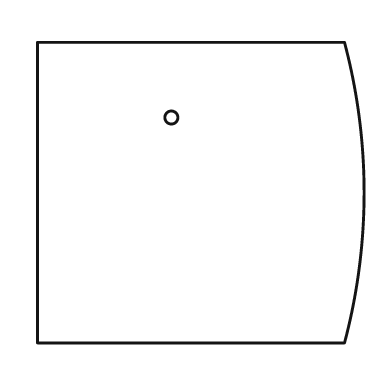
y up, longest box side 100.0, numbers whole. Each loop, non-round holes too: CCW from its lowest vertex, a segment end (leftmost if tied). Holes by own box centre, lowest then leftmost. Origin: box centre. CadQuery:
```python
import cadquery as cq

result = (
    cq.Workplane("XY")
    .moveTo(-50.0, -46.0)
    .lineTo(44.0, -46.0)
    .threePointArc((50.0, 0.0), (44.0, 46.0))
    .lineTo(-50.0, 46.0)
    .close()
    .moveTo(-9.0, 23.0)
    .circle(2.0)
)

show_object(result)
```